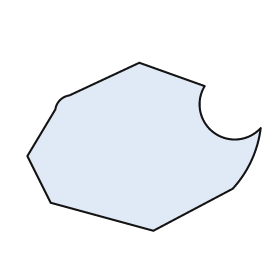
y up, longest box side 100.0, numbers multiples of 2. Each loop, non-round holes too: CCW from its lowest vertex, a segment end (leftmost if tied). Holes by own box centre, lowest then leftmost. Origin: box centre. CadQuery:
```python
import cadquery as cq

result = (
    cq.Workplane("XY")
    .moveTo(4.0, -36.0)
    .lineTo(38.0, -18.0)
    .threePointArc((46.0, -6.0), (50.0, 8.0))
    .threePointArc((30.0, 6.0), (26.0, 26.0))
    .lineTo(-2.0, 36.0)
    .lineTo(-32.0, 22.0)
    .threePointArc((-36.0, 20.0), (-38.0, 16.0))
    .lineTo(-50.0, -4.0)
    .lineTo(-40.0, -24.0)
    .close()
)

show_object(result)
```